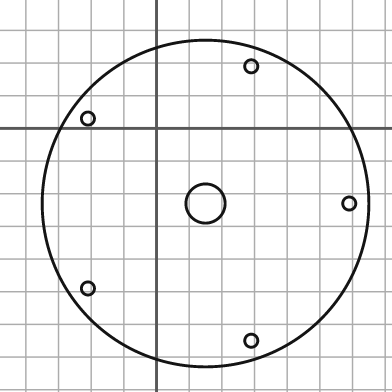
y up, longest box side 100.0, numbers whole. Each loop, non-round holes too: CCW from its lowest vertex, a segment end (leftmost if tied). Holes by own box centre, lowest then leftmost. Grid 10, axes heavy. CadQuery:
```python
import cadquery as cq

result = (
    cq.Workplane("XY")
    .moveTo(15.0, -23.0)
    .circle(50.0)
    .moveTo(29.0, -65.0)
    .circle(2.0)
    .moveTo(-21.0, -49.0)
    .circle(2.0)
    .moveTo(15.0, -23.0)
    .circle(6.0)
    .moveTo(59.0, -23.0)
    .circle(2.0)
    .moveTo(-21.0, 3.0)
    .circle(2.0)
    .moveTo(29.0, 19.0)
    .circle(2.0)
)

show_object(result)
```